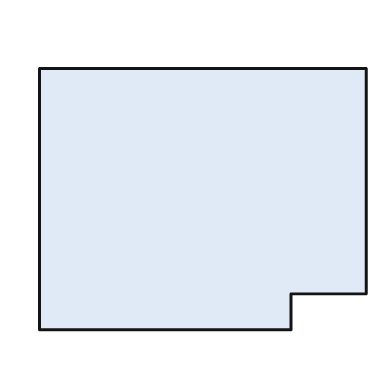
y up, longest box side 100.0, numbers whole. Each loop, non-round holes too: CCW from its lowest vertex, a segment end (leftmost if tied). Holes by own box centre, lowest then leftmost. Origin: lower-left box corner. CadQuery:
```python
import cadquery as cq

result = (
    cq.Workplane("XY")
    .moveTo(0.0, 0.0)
    .lineTo(77.0, 0.0)
    .lineTo(77.0, 11.0)
    .lineTo(100.0, 11.0)
    .lineTo(100.0, 80.0)
    .lineTo(0.0, 80.0)
    .close()
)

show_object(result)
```